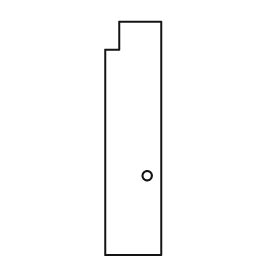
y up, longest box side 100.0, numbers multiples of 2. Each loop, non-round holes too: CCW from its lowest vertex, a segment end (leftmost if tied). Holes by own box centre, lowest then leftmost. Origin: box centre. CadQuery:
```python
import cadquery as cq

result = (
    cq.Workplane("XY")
    .moveTo(-12.0, -50.0)
    .lineTo(12.0, -50.0)
    .lineTo(12.0, 50.0)
    .lineTo(-6.0, 50.0)
    .lineTo(-6.0, 38.0)
    .lineTo(-12.0, 38.0)
    .close()
    .moveTo(6.0, -16.0)
    .circle(2.0)
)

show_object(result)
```